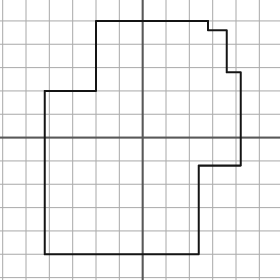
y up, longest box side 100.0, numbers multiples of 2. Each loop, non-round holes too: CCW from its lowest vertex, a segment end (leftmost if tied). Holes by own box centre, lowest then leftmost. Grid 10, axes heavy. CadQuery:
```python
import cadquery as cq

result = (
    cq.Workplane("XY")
    .moveTo(-42.0, -50.0)
    .lineTo(24.0, -50.0)
    .lineTo(24.0, -12.0)
    .lineTo(42.0, -12.0)
    .lineTo(42.0, 28.0)
    .lineTo(36.0, 28.0)
    .lineTo(36.0, 46.0)
    .lineTo(28.0, 46.0)
    .lineTo(28.0, 50.0)
    .lineTo(-20.0, 50.0)
    .lineTo(-20.0, 20.0)
    .lineTo(-42.0, 20.0)
    .close()
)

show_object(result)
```